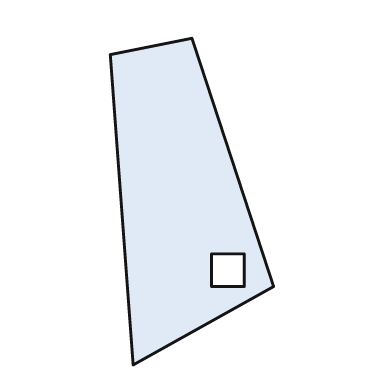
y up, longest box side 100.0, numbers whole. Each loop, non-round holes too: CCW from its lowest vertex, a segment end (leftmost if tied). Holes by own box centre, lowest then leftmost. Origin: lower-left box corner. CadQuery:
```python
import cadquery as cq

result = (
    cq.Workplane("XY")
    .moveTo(7.0, 0.0)
    .lineTo(50.0, 24.0)
    .lineTo(25.0, 100.0)
    .lineTo(0.0, 95.0)
    .close()
    .moveTo(31.0, 24.0)
    .lineTo(41.0, 24.0)
    .lineTo(41.0, 34.0)
    .lineTo(31.0, 34.0)
    .close()
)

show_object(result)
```